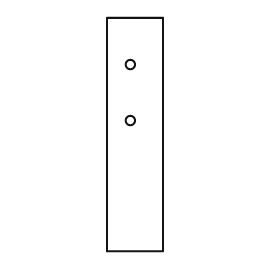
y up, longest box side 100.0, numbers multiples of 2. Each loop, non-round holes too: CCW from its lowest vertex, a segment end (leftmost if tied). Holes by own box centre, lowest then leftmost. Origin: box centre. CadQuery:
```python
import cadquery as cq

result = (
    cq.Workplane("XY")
    .moveTo(-12.0, -50.0)
    .lineTo(12.0, -50.0)
    .lineTo(12.0, 50.0)
    .lineTo(-12.0, 50.0)
    .close()
    .moveTo(-2.0, 6.0)
    .circle(2.0)
    .moveTo(-2.0, 30.0)
    .circle(2.0)
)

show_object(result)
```